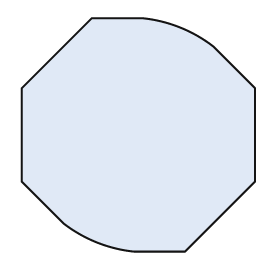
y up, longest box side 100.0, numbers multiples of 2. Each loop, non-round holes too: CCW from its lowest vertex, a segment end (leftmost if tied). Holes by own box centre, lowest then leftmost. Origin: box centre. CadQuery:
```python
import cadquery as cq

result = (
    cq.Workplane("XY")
    .moveTo(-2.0, -50.0)
    .lineTo(20.0, -50.0)
    .lineTo(50.0, -20.0)
    .lineTo(50.0, 20.0)
    .lineTo(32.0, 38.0)
    .threePointArc((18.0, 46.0), (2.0, 50.0))
    .lineTo(-20.0, 50.0)
    .lineTo(-50.0, 20.0)
    .lineTo(-50.0, -20.0)
    .lineTo(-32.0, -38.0)
    .threePointArc((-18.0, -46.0), (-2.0, -50.0))
    .close()
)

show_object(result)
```